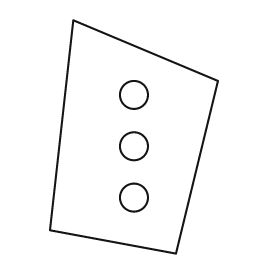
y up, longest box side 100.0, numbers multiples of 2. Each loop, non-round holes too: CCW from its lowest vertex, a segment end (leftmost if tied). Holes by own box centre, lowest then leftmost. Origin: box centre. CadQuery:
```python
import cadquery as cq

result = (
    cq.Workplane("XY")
    .moveTo(18.0, -50.0)
    .lineTo(36.0, 24.0)
    .lineTo(-26.0, 50.0)
    .lineTo(-36.0, -40.0)
    .close()
    .moveTo(0.0, -26.0)
    .circle(6.0)
    .moveTo(0.0, -4.0)
    .circle(6.0)
    .moveTo(0.0, 18.0)
    .circle(6.0)
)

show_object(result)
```